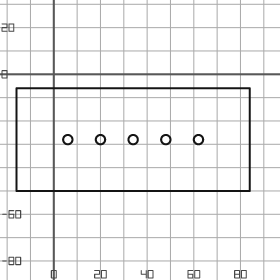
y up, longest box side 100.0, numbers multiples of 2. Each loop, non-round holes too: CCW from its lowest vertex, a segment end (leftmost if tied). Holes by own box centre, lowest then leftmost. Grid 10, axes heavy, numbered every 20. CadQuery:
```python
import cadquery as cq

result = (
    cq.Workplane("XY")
    .moveTo(-16.0, -50.0)
    .lineTo(84.0, -50.0)
    .lineTo(84.0, -6.0)
    .lineTo(-16.0, -6.0)
    .close()
    .moveTo(6.0, -28.0)
    .circle(2.0)
    .moveTo(20.0, -28.0)
    .circle(2.0)
    .moveTo(34.0, -28.0)
    .circle(2.0)
    .moveTo(48.0, -28.0)
    .circle(2.0)
    .moveTo(62.0, -28.0)
    .circle(2.0)
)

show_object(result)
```